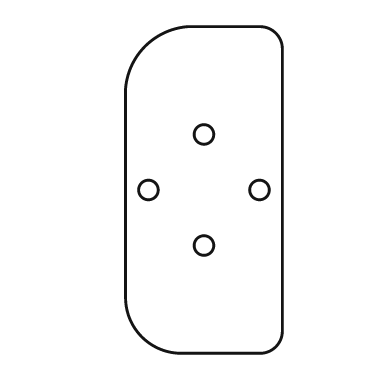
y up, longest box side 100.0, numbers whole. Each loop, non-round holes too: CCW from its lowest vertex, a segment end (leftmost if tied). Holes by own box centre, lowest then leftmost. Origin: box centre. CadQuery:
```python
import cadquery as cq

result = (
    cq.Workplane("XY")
    .moveTo(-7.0, -50.0)
    .lineTo(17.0, -50.0)
    .threePointArc((22.0, -48.0), (24.0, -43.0))
    .lineTo(24.0, 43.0)
    .threePointArc((22.0, 48.0), (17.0, 50.0))
    .lineTo(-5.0, 50.0)
    .threePointArc((-18.0, 44.0), (-24.0, 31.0))
    .lineTo(-24.0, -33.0)
    .threePointArc((-19.0, -45.0), (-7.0, -50.0))
    .close()
    .moveTo(0.0, -17.0)
    .circle(3.0)
    .moveTo(-17.0, 0.0)
    .circle(3.0)
    .moveTo(17.0, 0.0)
    .circle(3.0)
    .moveTo(0.0, 17.0)
    .circle(3.0)
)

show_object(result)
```